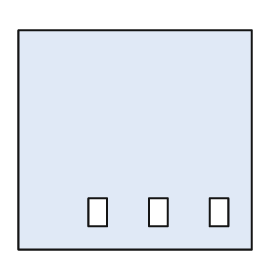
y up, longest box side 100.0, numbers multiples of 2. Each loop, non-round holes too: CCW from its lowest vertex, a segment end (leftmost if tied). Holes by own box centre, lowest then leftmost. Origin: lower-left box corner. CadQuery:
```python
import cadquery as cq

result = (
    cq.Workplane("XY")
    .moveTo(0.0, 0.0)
    .lineTo(100.0, 0.0)
    .lineTo(100.0, 94.0)
    .lineTo(0.0, 94.0)
    .close()
    .moveTo(30.0, 10.0)
    .lineTo(38.0, 10.0)
    .lineTo(38.0, 22.0)
    .lineTo(30.0, 22.0)
    .close()
    .moveTo(56.0, 10.0)
    .lineTo(64.0, 10.0)
    .lineTo(64.0, 22.0)
    .lineTo(56.0, 22.0)
    .close()
    .moveTo(82.0, 10.0)
    .lineTo(90.0, 10.0)
    .lineTo(90.0, 22.0)
    .lineTo(82.0, 22.0)
    .close()
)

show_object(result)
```